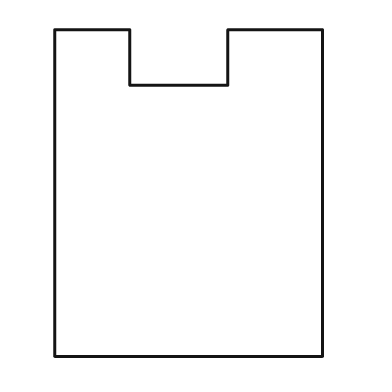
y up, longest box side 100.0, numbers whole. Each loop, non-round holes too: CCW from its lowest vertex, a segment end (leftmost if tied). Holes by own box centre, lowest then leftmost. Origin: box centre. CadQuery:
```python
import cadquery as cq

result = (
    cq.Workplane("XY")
    .moveTo(-41.0, -50.0)
    .lineTo(41.0, -50.0)
    .lineTo(41.0, 50.0)
    .lineTo(12.0, 50.0)
    .lineTo(12.0, 33.0)
    .lineTo(-18.0, 33.0)
    .lineTo(-18.0, 50.0)
    .lineTo(-41.0, 50.0)
    .close()
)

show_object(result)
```